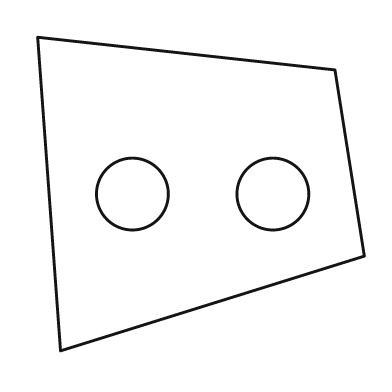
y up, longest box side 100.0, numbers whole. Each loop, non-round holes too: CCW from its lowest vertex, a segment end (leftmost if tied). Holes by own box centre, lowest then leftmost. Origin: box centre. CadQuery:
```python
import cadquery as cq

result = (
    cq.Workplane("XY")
    .moveTo(-43.0, -48.0)
    .lineTo(50.0, -19.0)
    .lineTo(41.0, 38.0)
    .lineTo(-50.0, 48.0)
    .close()
    .moveTo(-21.0, 0.0)
    .circle(11.0)
    .moveTo(22.0, 0.0)
    .circle(11.0)
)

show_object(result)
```